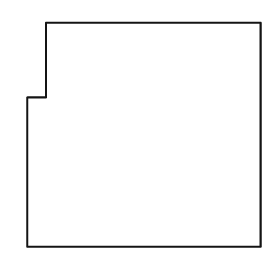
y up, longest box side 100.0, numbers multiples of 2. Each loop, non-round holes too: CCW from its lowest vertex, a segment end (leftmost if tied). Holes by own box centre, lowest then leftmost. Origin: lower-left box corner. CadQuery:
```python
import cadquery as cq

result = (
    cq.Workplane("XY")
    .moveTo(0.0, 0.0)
    .lineTo(100.0, 0.0)
    .lineTo(100.0, 96.0)
    .lineTo(8.0, 96.0)
    .lineTo(8.0, 64.0)
    .lineTo(0.0, 64.0)
    .close()
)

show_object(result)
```